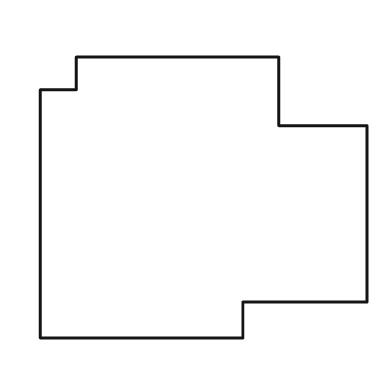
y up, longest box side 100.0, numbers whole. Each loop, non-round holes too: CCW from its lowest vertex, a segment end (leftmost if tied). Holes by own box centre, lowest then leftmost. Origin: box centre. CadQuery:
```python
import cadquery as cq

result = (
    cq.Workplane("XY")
    .moveTo(-50.0, -43.0)
    .lineTo(12.0, -43.0)
    .lineTo(12.0, -32.0)
    .lineTo(50.0, -32.0)
    .lineTo(50.0, 22.0)
    .lineTo(23.0, 22.0)
    .lineTo(23.0, 43.0)
    .lineTo(-39.0, 43.0)
    .lineTo(-39.0, 33.0)
    .lineTo(-50.0, 33.0)
    .close()
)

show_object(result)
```